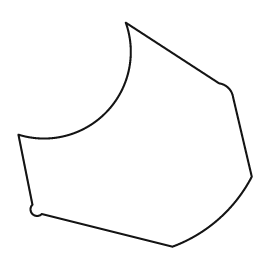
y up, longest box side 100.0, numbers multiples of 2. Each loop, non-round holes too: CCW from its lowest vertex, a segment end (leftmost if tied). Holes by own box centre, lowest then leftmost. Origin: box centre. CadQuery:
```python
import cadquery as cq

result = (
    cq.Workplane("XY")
    .moveTo(16.0, -48.0)
    .threePointArc((36.0, -36.0), (50.0, -18.0))
    .lineTo(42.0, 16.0)
    .threePointArc((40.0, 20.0), (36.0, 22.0))
    .lineTo(-4.0, 48.0)
    .threePointArc((-12.0, 10.0), (-50.0, 0.0))
    .lineTo(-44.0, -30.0)
    .threePointArc((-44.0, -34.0), (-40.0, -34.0))
    .close()
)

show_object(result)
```